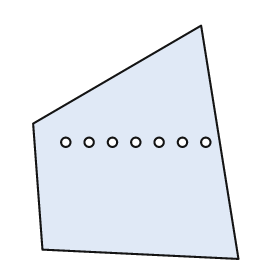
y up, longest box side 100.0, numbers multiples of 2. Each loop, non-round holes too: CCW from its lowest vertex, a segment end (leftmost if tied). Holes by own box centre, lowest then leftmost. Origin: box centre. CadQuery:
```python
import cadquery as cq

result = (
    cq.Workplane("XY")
    .moveTo(44.0, -50.0)
    .lineTo(28.0, 50.0)
    .lineTo(-44.0, 8.0)
    .lineTo(-40.0, -46.0)
    .close()
    .moveTo(-30.0, 0.0)
    .circle(2.0)
    .moveTo(-20.0, 0.0)
    .circle(2.0)
    .moveTo(-10.0, 0.0)
    .circle(2.0)
    .moveTo(0.0, 0.0)
    .circle(2.0)
    .moveTo(10.0, 0.0)
    .circle(2.0)
    .moveTo(20.0, 0.0)
    .circle(2.0)
    .moveTo(30.0, 0.0)
    .circle(2.0)
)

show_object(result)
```